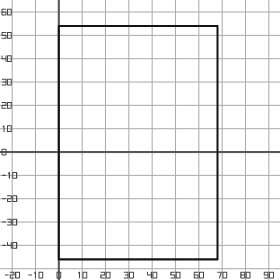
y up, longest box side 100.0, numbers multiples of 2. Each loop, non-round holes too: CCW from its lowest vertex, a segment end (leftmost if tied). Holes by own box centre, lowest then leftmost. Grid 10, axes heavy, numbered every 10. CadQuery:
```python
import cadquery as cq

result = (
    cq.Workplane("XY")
    .moveTo(0.0, -46.0)
    .lineTo(68.0, -46.0)
    .lineTo(68.0, 54.0)
    .lineTo(0.0, 54.0)
    .close()
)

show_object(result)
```